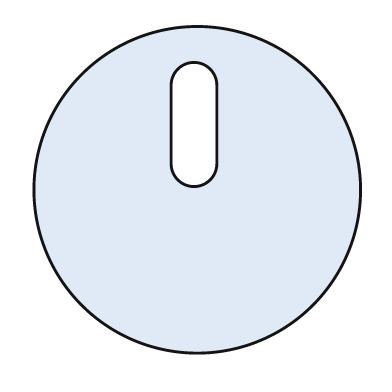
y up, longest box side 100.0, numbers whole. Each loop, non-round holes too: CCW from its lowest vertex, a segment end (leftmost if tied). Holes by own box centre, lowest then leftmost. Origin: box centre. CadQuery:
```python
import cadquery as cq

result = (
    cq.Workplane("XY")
    .moveTo(0.0, 0.0)
    .circle(50.0)
    .moveTo(-8.0, 8.0)
    .threePointArc((-1.0, 1.0), (6.0, 8.0))
    .lineTo(6.0, 32.0)
    .threePointArc((-1.0, 39.0), (-8.0, 32.0))
    .close()
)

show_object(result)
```